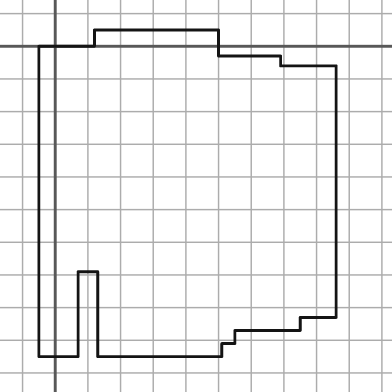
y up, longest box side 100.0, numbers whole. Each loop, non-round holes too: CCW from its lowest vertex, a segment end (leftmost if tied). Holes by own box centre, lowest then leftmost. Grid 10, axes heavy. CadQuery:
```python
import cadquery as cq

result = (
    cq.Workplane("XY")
    .moveTo(-5.0, -95.0)
    .lineTo(7.0, -95.0)
    .lineTo(7.0, -69.0)
    .lineTo(13.0, -69.0)
    .lineTo(13.0, -95.0)
    .lineTo(51.0, -95.0)
    .lineTo(51.0, -91.0)
    .lineTo(55.0, -91.0)
    .lineTo(55.0, -87.0)
    .lineTo(75.0, -87.0)
    .lineTo(75.0, -83.0)
    .lineTo(86.0, -83.0)
    .lineTo(86.0, -6.0)
    .lineTo(69.0, -6.0)
    .lineTo(69.0, -3.0)
    .lineTo(50.0, -3.0)
    .lineTo(50.0, 5.0)
    .lineTo(12.0, 5.0)
    .lineTo(12.0, 0.0)
    .lineTo(-5.0, 0.0)
    .close()
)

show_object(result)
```